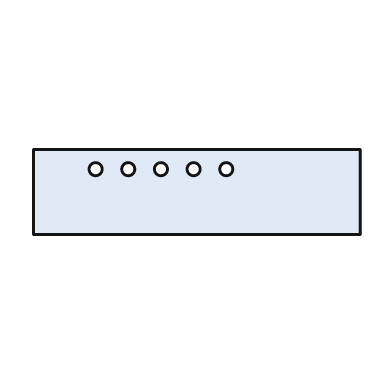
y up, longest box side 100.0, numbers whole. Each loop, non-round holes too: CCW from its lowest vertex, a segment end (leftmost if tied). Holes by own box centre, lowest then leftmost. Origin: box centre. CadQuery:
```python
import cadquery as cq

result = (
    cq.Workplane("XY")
    .moveTo(-50.0, -13.0)
    .lineTo(50.0, -13.0)
    .lineTo(50.0, 13.0)
    .lineTo(-50.0, 13.0)
    .close()
    .moveTo(-31.0, 7.0)
    .circle(2.0)
    .moveTo(-21.0, 7.0)
    .circle(2.0)
    .moveTo(-11.0, 7.0)
    .circle(2.0)
    .moveTo(-1.0, 7.0)
    .circle(2.0)
    .moveTo(9.0, 7.0)
    .circle(2.0)
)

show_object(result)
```